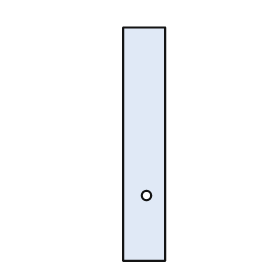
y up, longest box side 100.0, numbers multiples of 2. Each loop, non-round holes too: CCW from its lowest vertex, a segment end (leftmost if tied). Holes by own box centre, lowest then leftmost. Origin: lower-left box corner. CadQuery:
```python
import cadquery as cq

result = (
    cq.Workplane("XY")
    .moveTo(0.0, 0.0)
    .lineTo(18.0, 0.0)
    .lineTo(18.0, 100.0)
    .lineTo(0.0, 100.0)
    .close()
    .moveTo(10.0, 28.0)
    .circle(2.0)
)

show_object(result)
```